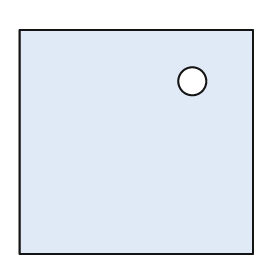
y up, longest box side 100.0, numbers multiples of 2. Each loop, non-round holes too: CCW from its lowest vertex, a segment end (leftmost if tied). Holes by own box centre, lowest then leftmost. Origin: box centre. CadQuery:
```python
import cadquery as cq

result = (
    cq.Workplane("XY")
    .moveTo(-50.0, -48.0)
    .lineTo(50.0, -48.0)
    .lineTo(50.0, 48.0)
    .lineTo(-50.0, 48.0)
    .close()
    .moveTo(24.0, 26.0)
    .circle(6.0)
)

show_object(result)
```